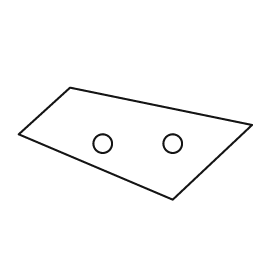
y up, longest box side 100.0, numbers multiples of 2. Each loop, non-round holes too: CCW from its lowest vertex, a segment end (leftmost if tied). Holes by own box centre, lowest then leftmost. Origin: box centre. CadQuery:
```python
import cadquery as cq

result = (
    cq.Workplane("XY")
    .moveTo(16.0, -24.0)
    .lineTo(50.0, 8.0)
    .lineTo(-28.0, 24.0)
    .lineTo(-50.0, 4.0)
    .close()
    .moveTo(-14.0, 0.0)
    .circle(4.0)
    .moveTo(16.0, 0.0)
    .circle(4.0)
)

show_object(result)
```